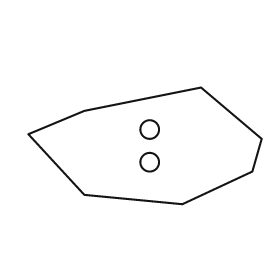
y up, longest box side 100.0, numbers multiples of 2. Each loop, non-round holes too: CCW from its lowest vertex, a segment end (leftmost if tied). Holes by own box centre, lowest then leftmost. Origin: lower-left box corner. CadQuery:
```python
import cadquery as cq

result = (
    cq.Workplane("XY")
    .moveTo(66.0, 0.0)
    .lineTo(96.0, 14.0)
    .lineTo(100.0, 28.0)
    .lineTo(74.0, 50.0)
    .lineTo(24.0, 40.0)
    .lineTo(0.0, 30.0)
    .lineTo(24.0, 4.0)
    .close()
    .moveTo(52.0, 18.0)
    .circle(4.0)
    .moveTo(52.0, 32.0)
    .circle(4.0)
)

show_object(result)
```